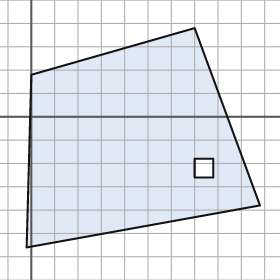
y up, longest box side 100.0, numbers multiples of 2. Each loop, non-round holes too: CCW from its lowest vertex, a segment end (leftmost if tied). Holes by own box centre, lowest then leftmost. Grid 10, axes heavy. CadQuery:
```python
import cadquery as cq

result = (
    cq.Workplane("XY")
    .moveTo(-2.0, -56.0)
    .lineTo(98.0, -38.0)
    .lineTo(70.0, 38.0)
    .lineTo(0.0, 18.0)
    .close()
    .moveTo(70.0, -26.0)
    .lineTo(78.0, -26.0)
    .lineTo(78.0, -18.0)
    .lineTo(70.0, -18.0)
    .close()
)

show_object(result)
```